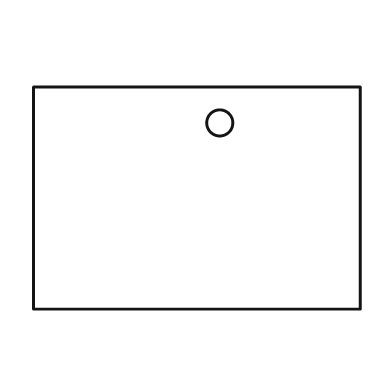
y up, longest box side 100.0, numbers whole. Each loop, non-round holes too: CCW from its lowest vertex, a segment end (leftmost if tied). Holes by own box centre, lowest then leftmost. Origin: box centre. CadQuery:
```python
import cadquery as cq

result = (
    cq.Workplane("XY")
    .moveTo(-50.0, -34.0)
    .lineTo(50.0, -34.0)
    .lineTo(50.0, 34.0)
    .lineTo(-50.0, 34.0)
    .close()
    .moveTo(7.0, 23.0)
    .circle(4.0)
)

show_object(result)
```